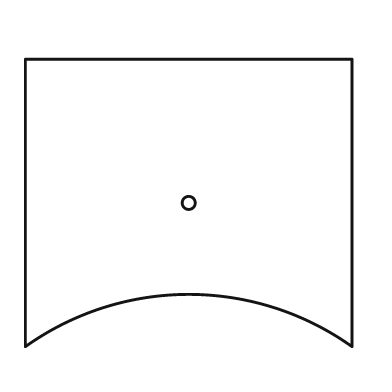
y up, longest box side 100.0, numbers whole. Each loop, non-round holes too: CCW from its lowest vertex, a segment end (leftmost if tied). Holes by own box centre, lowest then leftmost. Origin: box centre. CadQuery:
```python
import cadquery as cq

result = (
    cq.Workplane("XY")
    .moveTo(-50.0, -44.0)
    .threePointArc((0.0, -28.0), (50.0, -44.0))
    .lineTo(50.0, 44.0)
    .lineTo(-50.0, 44.0)
    .close()
    .moveTo(0.0, 0.0)
    .circle(2.0)
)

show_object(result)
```